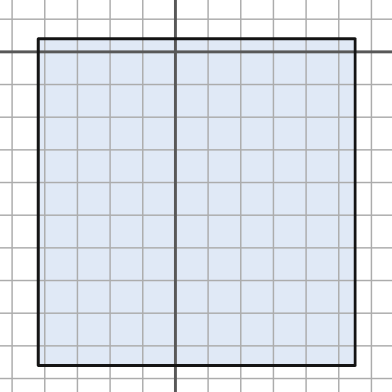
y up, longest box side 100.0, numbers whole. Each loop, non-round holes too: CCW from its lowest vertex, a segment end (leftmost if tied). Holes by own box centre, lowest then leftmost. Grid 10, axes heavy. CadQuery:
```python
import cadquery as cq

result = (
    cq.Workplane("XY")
    .moveTo(-42.0, -96.0)
    .lineTo(55.0, -96.0)
    .lineTo(55.0, 4.0)
    .lineTo(-42.0, 4.0)
    .close()
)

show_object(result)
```